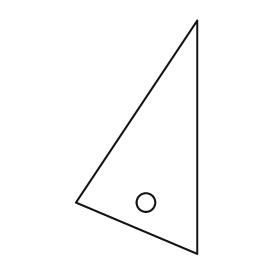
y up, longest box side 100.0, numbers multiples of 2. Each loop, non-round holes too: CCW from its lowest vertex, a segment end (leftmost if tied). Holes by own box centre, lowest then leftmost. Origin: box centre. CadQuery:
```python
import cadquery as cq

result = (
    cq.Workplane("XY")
    .moveTo(26.0, -50.0)
    .lineTo(26.0, 50.0)
    .lineTo(-26.0, -28.0)
    .close()
    .moveTo(4.0, -28.0)
    .circle(4.0)
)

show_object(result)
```